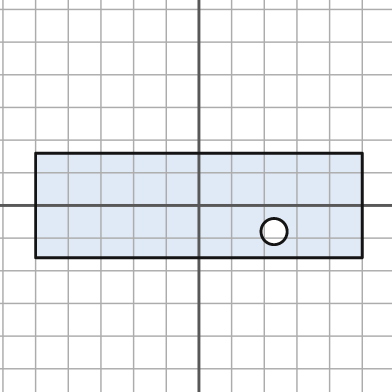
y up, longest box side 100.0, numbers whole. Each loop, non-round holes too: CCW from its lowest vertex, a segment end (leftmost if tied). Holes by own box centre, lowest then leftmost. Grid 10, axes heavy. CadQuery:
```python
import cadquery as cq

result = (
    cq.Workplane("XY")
    .moveTo(-50.0, -16.0)
    .lineTo(50.0, -16.0)
    .lineTo(50.0, 16.0)
    .lineTo(-50.0, 16.0)
    .close()
    .moveTo(23.0, -8.0)
    .circle(4.0)
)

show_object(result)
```